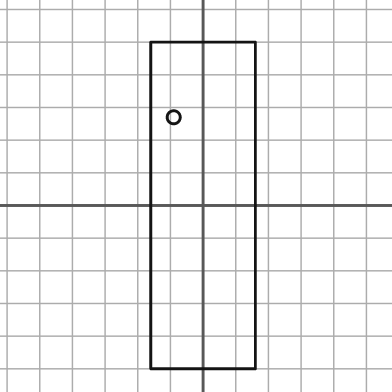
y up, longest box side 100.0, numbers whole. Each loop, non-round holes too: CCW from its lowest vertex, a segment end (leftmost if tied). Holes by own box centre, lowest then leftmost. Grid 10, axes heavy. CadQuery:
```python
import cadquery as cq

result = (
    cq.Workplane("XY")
    .moveTo(-16.0, -50.0)
    .lineTo(16.0, -50.0)
    .lineTo(16.0, 50.0)
    .lineTo(-16.0, 50.0)
    .close()
    .moveTo(-9.0, 27.0)
    .circle(2.0)
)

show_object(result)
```